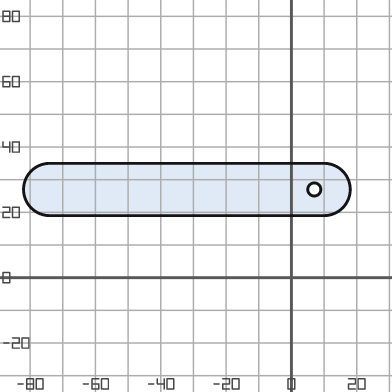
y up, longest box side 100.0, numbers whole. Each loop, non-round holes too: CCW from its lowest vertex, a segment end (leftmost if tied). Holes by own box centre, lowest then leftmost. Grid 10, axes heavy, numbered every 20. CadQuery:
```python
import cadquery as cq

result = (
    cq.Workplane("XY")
    .moveTo(-74.0, 19.0)
    .lineTo(10.0, 19.0)
    .threePointArc((18.0, 27.0), (10.0, 35.0))
    .lineTo(-74.0, 35.0)
    .threePointArc((-82.0, 27.0), (-74.0, 19.0))
    .close()
    .moveTo(7.0, 27.0)
    .circle(2.0)
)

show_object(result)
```